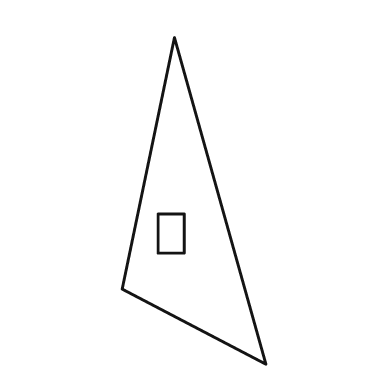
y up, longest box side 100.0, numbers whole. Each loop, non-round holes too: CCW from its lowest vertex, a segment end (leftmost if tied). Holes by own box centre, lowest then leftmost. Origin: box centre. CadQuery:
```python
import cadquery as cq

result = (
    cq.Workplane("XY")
    .moveTo(22.0, -50.0)
    .lineTo(-6.0, 50.0)
    .lineTo(-22.0, -27.0)
    .close()
    .moveTo(-11.0, -16.0)
    .lineTo(-3.0, -16.0)
    .lineTo(-3.0, -4.0)
    .lineTo(-11.0, -4.0)
    .close()
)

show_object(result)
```